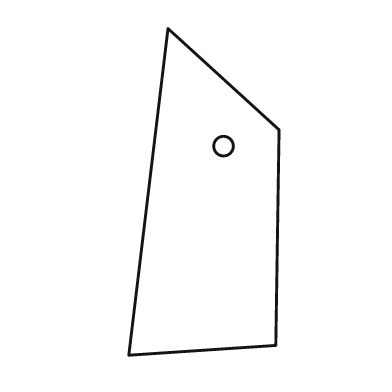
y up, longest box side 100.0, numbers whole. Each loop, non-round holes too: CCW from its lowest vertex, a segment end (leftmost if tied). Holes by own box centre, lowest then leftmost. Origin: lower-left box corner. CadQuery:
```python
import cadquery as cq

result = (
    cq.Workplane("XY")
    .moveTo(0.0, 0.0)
    .lineTo(45.0, 3.0)
    .lineTo(46.0, 69.0)
    .lineTo(12.0, 100.0)
    .close()
    .moveTo(29.0, 64.0)
    .circle(3.0)
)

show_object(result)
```